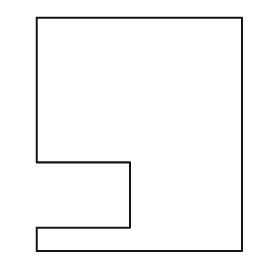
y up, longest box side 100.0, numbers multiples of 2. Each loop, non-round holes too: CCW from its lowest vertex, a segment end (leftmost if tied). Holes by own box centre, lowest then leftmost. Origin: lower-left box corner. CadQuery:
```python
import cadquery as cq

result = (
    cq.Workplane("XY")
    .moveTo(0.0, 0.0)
    .lineTo(88.0, 0.0)
    .lineTo(88.0, 100.0)
    .lineTo(0.0, 100.0)
    .lineTo(0.0, 38.0)
    .lineTo(40.0, 38.0)
    .lineTo(40.0, 10.0)
    .lineTo(0.0, 10.0)
    .close()
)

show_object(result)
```